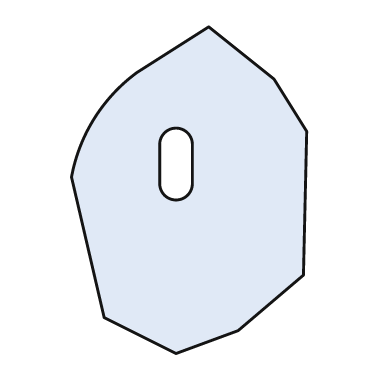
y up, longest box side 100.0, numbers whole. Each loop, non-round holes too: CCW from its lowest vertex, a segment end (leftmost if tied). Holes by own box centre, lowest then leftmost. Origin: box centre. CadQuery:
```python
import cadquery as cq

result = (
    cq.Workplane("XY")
    .moveTo(-4.0, -50.0)
    .lineTo(15.0, -43.0)
    .lineTo(35.0, -26.0)
    .lineTo(36.0, 18.0)
    .lineTo(26.0, 34.0)
    .lineTo(6.0, 50.0)
    .lineTo(-16.0, 36.0)
    .threePointArc((-29.0, 22.0), (-36.0, 4.0))
    .lineTo(-26.0, -39.0)
    .close()
    .moveTo(-9.0, 2.0)
    .threePointArc((-4.0, -3.0), (1.0, 2.0))
    .lineTo(1.0, 14.0)
    .threePointArc((-4.0, 19.0), (-9.0, 14.0))
    .close()
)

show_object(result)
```